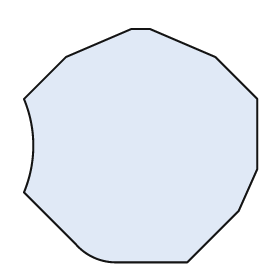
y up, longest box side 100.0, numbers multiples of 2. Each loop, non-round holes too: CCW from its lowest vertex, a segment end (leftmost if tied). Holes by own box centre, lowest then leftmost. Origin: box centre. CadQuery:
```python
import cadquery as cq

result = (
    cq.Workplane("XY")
    .moveTo(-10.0, -50.0)
    .lineTo(20.0, -50.0)
    .lineTo(42.0, -28.0)
    .lineTo(50.0, -10.0)
    .lineTo(50.0, 20.0)
    .lineTo(32.0, 38.0)
    .lineTo(4.0, 50.0)
    .lineTo(-4.0, 50.0)
    .lineTo(-32.0, 38.0)
    .lineTo(-50.0, 20.0)
    .threePointArc((-46.0, 0.0), (-50.0, -20.0))
    .lineTo(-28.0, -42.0)
    .threePointArc((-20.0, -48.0), (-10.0, -50.0))
    .close()
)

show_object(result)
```